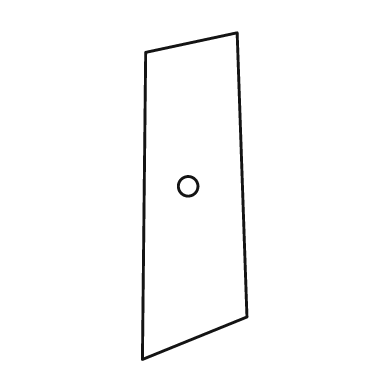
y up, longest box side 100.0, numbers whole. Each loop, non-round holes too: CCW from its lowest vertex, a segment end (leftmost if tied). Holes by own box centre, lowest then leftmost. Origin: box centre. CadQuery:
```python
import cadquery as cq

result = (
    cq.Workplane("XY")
    .moveTo(-16.0, -50.0)
    .lineTo(16.0, -37.0)
    .lineTo(13.0, 50.0)
    .lineTo(-15.0, 44.0)
    .close()
    .moveTo(-2.0, 3.0)
    .circle(3.0)
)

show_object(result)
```